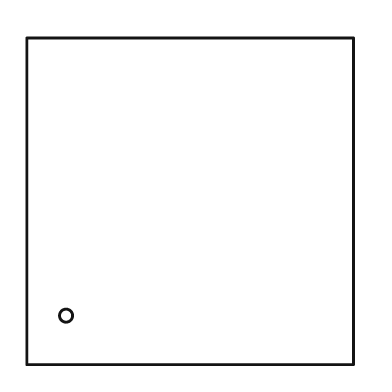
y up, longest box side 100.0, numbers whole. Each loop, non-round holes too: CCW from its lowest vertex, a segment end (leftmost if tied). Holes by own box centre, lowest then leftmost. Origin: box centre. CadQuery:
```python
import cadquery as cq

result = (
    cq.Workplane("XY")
    .moveTo(-50.0, -50.0)
    .lineTo(50.0, -50.0)
    .lineTo(50.0, 50.0)
    .lineTo(-50.0, 50.0)
    .close()
    .moveTo(-38.0, -35.0)
    .circle(2.0)
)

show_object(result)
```